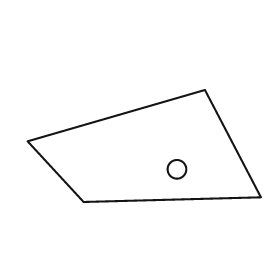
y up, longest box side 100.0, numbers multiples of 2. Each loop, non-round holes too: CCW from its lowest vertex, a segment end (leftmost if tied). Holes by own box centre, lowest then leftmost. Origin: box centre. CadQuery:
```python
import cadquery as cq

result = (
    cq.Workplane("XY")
    .moveTo(-26.0, -24.0)
    .lineTo(50.0, -22.0)
    .lineTo(26.0, 24.0)
    .lineTo(-50.0, 2.0)
    .close()
    .moveTo(14.0, -10.0)
    .circle(4.0)
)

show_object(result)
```